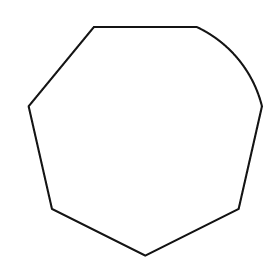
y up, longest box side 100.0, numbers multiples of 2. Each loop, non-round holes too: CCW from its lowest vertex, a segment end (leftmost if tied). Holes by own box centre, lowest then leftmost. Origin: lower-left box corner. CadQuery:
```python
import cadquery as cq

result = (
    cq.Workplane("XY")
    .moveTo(50.0, 0.0)
    .lineTo(90.0, 20.0)
    .lineTo(100.0, 64.0)
    .threePointArc((90.0, 84.0), (72.0, 98.0))
    .lineTo(28.0, 98.0)
    .lineTo(0.0, 64.0)
    .lineTo(10.0, 20.0)
    .close()
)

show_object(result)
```